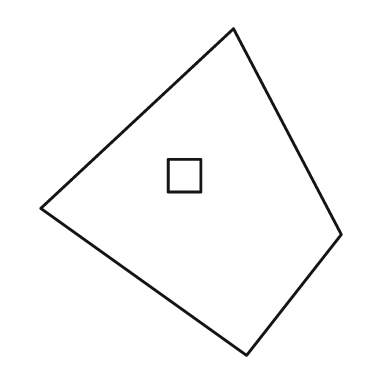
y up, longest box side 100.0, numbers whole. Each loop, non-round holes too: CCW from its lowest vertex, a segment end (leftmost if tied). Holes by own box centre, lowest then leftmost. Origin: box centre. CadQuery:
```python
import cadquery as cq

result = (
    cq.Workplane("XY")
    .moveTo(17.0, -50.0)
    .lineTo(46.0, -13.0)
    .lineTo(13.0, 50.0)
    .lineTo(-46.0, -5.0)
    .close()
    .moveTo(-7.0, 0.0)
    .lineTo(3.0, 0.0)
    .lineTo(3.0, 10.0)
    .lineTo(-7.0, 10.0)
    .close()
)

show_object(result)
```